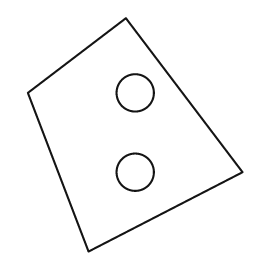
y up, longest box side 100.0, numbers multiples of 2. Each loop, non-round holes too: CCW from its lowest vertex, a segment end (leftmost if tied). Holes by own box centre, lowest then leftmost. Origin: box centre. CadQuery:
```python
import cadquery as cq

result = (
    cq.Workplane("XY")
    .moveTo(-20.0, -50.0)
    .lineTo(46.0, -16.0)
    .lineTo(-4.0, 50.0)
    .lineTo(-46.0, 18.0)
    .close()
    .moveTo(0.0, -16.0)
    .circle(8.0)
    .moveTo(0.0, 18.0)
    .circle(8.0)
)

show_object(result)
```